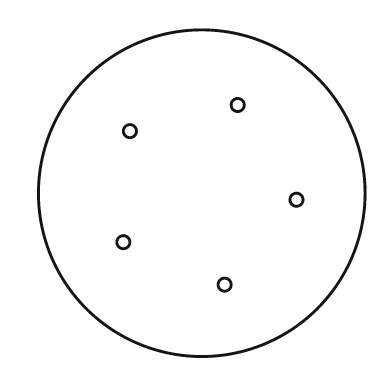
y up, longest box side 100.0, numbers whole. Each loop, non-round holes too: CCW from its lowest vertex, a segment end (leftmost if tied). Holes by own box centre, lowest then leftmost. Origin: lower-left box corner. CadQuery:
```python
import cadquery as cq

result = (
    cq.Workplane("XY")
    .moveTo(50.0, 50.0)
    .circle(50.0)
    .moveTo(57.0, 22.0)
    .circle(2.0)
    .moveTo(26.0, 35.0)
    .circle(2.0)
    .moveTo(79.0, 48.0)
    .circle(2.0)
    .moveTo(28.0, 69.0)
    .circle(2.0)
    .moveTo(61.0, 77.0)
    .circle(2.0)
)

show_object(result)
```